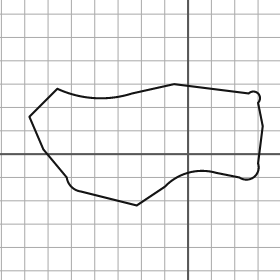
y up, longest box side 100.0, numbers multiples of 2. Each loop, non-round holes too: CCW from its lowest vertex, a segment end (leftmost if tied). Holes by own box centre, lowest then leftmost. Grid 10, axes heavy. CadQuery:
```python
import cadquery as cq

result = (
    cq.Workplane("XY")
    .moveTo(-22.0, -22.0)
    .lineTo(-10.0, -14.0)
    .threePointArc((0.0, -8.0), (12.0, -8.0))
    .lineTo(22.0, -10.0)
    .threePointArc((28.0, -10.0), (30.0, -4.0))
    .lineTo(32.0, 12.0)
    .lineTo(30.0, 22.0)
    .threePointArc((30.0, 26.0), (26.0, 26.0))
    .lineTo(-6.0, 30.0)
    .lineTo(-24.0, 26.0)
    .threePointArc((-40.0, 24.0), (-56.0, 28.0))
    .lineTo(-68.0, 16.0)
    .lineTo(-62.0, 2.0)
    .lineTo(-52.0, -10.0)
    .threePointArc((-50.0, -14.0), (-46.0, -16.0))
    .close()
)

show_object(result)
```